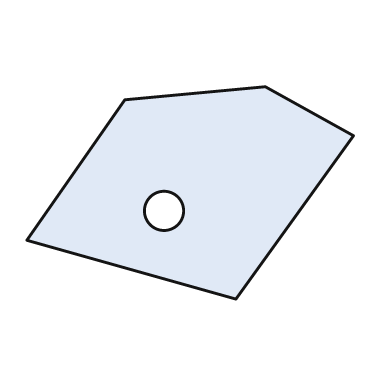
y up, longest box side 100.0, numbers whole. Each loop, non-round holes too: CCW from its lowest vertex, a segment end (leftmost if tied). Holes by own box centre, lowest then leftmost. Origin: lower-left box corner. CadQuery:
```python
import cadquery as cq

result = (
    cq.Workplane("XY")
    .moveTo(64.0, 0.0)
    .lineTo(100.0, 50.0)
    .lineTo(73.0, 65.0)
    .lineTo(30.0, 61.0)
    .lineTo(0.0, 18.0)
    .close()
    .moveTo(42.0, 27.0)
    .circle(6.0)
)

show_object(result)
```